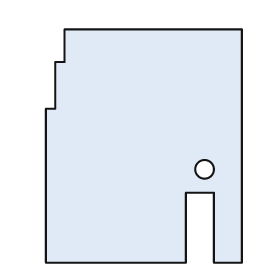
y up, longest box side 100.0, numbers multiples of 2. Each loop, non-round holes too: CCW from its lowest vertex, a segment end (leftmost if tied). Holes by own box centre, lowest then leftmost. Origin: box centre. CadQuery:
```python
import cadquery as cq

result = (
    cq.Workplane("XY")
    .moveTo(-42.0, -50.0)
    .lineTo(18.0, -50.0)
    .lineTo(18.0, -20.0)
    .lineTo(30.0, -20.0)
    .lineTo(30.0, -50.0)
    .lineTo(42.0, -50.0)
    .lineTo(42.0, 50.0)
    .lineTo(-34.0, 50.0)
    .lineTo(-34.0, 36.0)
    .lineTo(-38.0, 36.0)
    .lineTo(-38.0, 16.0)
    .lineTo(-42.0, 16.0)
    .close()
    .moveTo(26.0, -10.0)
    .circle(4.0)
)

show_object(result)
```